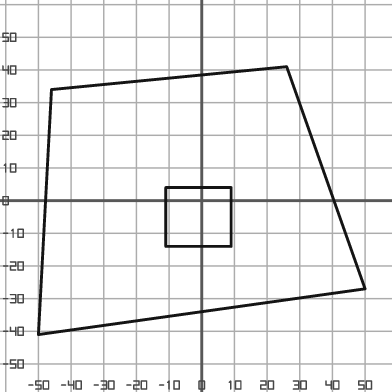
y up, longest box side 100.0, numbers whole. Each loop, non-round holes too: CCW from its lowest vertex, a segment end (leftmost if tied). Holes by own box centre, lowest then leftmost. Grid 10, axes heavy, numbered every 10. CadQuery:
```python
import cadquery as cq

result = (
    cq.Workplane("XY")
    .moveTo(-50.0, -41.0)
    .lineTo(50.0, -27.0)
    .lineTo(26.0, 41.0)
    .lineTo(-46.0, 34.0)
    .close()
    .moveTo(-11.0, -14.0)
    .lineTo(9.0, -14.0)
    .lineTo(9.0, 4.0)
    .lineTo(-11.0, 4.0)
    .close()
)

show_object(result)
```